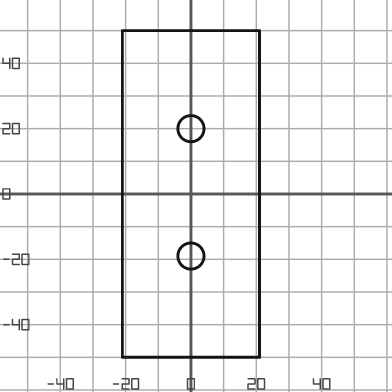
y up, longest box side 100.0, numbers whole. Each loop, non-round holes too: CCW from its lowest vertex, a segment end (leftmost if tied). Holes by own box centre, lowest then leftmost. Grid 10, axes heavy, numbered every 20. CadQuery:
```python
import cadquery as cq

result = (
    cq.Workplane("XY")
    .moveTo(-21.0, -50.0)
    .lineTo(21.0, -50.0)
    .lineTo(21.0, 50.0)
    .lineTo(-21.0, 50.0)
    .close()
    .moveTo(0.0, -19.0)
    .circle(4.0)
    .moveTo(0.0, 20.0)
    .circle(4.0)
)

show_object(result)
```